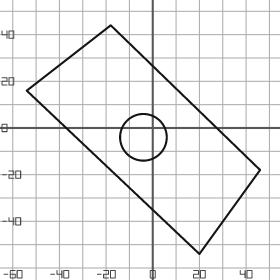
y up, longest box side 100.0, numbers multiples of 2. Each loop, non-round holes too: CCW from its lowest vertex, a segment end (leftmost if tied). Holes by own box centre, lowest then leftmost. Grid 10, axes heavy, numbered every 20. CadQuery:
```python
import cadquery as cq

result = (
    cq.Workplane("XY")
    .moveTo(20.0, -54.0)
    .lineTo(46.0, -18.0)
    .lineTo(-18.0, 44.0)
    .lineTo(-54.0, 16.0)
    .close()
    .moveTo(-4.0, -4.0)
    .circle(10.0)
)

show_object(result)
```